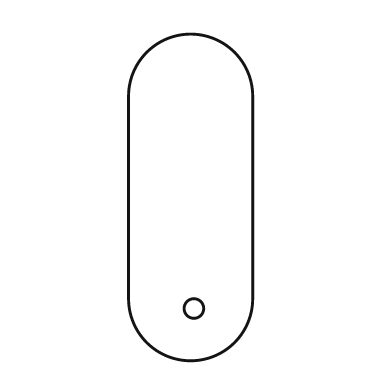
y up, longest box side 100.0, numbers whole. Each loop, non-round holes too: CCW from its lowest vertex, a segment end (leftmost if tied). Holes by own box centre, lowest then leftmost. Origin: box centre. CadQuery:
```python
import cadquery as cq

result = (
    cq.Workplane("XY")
    .moveTo(-19.0, -31.0)
    .threePointArc((0.0, -50.0), (19.0, -31.0))
    .lineTo(19.0, 31.0)
    .threePointArc((0.0, 50.0), (-19.0, 31.0))
    .close()
    .moveTo(1.0, -34.0)
    .circle(3.0)
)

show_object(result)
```